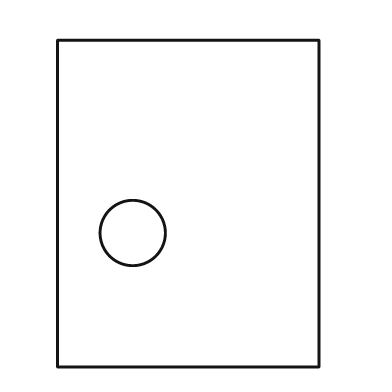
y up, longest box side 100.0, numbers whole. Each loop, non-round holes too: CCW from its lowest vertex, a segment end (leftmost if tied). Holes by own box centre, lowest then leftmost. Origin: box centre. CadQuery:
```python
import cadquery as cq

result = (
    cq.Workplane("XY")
    .moveTo(-40.0, -50.0)
    .lineTo(40.0, -50.0)
    .lineTo(40.0, 50.0)
    .lineTo(-40.0, 50.0)
    .close()
    .moveTo(-17.0, -9.0)
    .circle(10.0)
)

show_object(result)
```